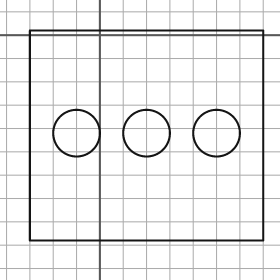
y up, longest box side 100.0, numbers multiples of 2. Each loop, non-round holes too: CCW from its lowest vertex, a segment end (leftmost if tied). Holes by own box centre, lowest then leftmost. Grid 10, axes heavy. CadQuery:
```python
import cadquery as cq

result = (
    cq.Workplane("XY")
    .moveTo(-30.0, -88.0)
    .lineTo(70.0, -88.0)
    .lineTo(70.0, 2.0)
    .lineTo(-30.0, 2.0)
    .close()
    .moveTo(-10.0, -42.0)
    .circle(10.0)
    .moveTo(20.0, -42.0)
    .circle(10.0)
    .moveTo(50.0, -42.0)
    .circle(10.0)
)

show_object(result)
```